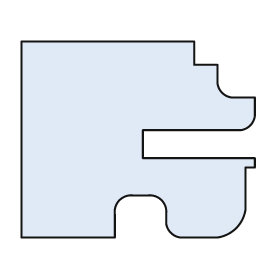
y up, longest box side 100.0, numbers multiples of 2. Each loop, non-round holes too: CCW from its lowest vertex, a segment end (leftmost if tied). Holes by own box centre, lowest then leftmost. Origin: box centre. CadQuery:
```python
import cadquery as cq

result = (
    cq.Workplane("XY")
    .moveTo(-50.0, -42.0)
    .lineTo(-10.0, -42.0)
    .lineTo(-10.0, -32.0)
    .threePointArc((-8.0, -26.0), (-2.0, -24.0))
    .lineTo(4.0, -24.0)
    .threePointArc((10.0, -26.0), (12.0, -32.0))
    .lineTo(12.0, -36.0)
    .threePointArc((14.0, -40.0), (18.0, -42.0))
    .lineTo(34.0, -42.0)
    .threePointArc((42.0, -38.0), (46.0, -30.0))
    .lineTo(46.0, -12.0)
    .lineTo(50.0, -12.0)
    .lineTo(50.0, -8.0)
    .lineTo(2.0, -8.0)
    .lineTo(2.0, 4.0)
    .lineTo(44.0, 4.0)
    .threePointArc((48.0, 6.0), (50.0, 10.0))
    .lineTo(50.0, 18.0)
    .lineTo(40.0, 18.0)
    .threePointArc((36.0, 20.0), (34.0, 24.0))
    .lineTo(34.0, 32.0)
    .lineTo(24.0, 32.0)
    .lineTo(24.0, 42.0)
    .lineTo(-50.0, 42.0)
    .close()
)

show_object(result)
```